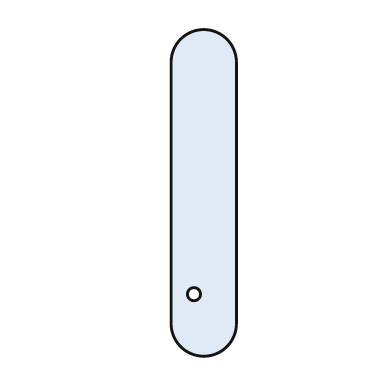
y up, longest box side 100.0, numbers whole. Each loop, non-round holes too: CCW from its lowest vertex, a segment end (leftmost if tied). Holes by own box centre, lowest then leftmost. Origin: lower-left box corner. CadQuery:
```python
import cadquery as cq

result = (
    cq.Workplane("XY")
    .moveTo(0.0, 10.0)
    .threePointArc((10.0, 0.0), (20.0, 10.0))
    .lineTo(20.0, 90.0)
    .threePointArc((10.0, 100.0), (0.0, 90.0))
    .close()
    .moveTo(7.0, 19.0)
    .circle(2.0)
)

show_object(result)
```